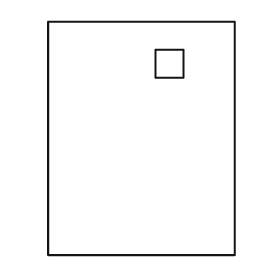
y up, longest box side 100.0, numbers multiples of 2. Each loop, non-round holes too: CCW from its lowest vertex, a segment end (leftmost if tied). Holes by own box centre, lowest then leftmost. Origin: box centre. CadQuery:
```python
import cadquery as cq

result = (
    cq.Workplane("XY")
    .moveTo(-40.0, -50.0)
    .lineTo(40.0, -50.0)
    .lineTo(40.0, 50.0)
    .lineTo(-40.0, 50.0)
    .close()
    .moveTo(6.0, 26.0)
    .lineTo(18.0, 26.0)
    .lineTo(18.0, 38.0)
    .lineTo(6.0, 38.0)
    .close()
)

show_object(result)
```